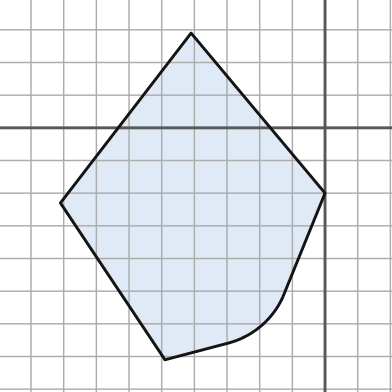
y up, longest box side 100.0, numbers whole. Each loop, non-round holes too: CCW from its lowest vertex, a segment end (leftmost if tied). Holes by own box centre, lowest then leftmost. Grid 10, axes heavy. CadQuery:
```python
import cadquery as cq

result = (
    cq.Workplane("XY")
    .moveTo(-49.0, -71.0)
    .lineTo(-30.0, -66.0)
    .threePointArc((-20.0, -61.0), (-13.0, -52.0))
    .lineTo(0.0, -20.0)
    .lineTo(-41.0, 29.0)
    .lineTo(-81.0, -23.0)
    .close()
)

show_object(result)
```